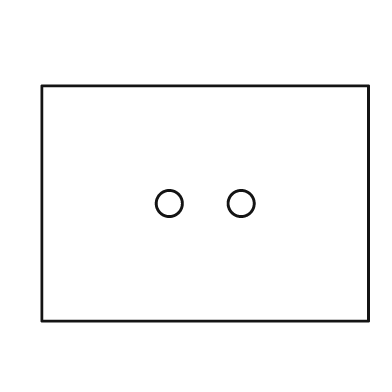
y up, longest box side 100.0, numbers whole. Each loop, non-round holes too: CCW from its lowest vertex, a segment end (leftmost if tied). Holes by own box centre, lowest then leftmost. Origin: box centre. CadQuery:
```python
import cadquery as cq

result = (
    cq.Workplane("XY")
    .moveTo(-50.0, -36.0)
    .lineTo(50.0, -36.0)
    .lineTo(50.0, 36.0)
    .lineTo(-50.0, 36.0)
    .close()
    .moveTo(-11.0, 0.0)
    .circle(4.0)
    .moveTo(11.0, 0.0)
    .circle(4.0)
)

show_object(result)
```